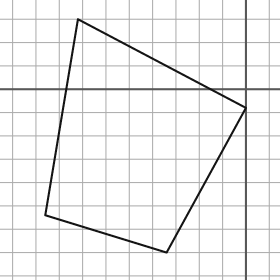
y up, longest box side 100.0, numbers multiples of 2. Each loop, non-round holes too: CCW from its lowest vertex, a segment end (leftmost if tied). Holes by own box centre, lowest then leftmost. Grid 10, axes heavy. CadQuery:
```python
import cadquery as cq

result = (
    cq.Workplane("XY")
    .moveTo(-34.0, -70.0)
    .lineTo(0.0, -8.0)
    .lineTo(-72.0, 30.0)
    .lineTo(-86.0, -54.0)
    .close()
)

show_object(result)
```